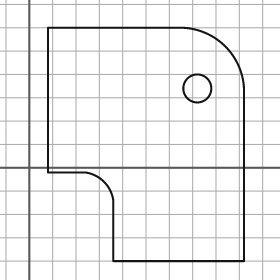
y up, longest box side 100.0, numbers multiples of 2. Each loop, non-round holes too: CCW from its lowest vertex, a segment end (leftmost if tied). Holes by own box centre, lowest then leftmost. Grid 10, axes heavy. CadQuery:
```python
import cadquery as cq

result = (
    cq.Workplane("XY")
    .moveTo(36.0, -40.0)
    .lineTo(92.0, -40.0)
    .lineTo(92.0, 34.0)
    .threePointArc((84.0, 52.0), (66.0, 60.0))
    .lineTo(8.0, 60.0)
    .lineTo(8.0, -2.0)
    .lineTo(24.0, -2.0)
    .threePointArc((32.0, -6.0), (36.0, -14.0))
    .close()
    .moveTo(72.0, 34.0)
    .circle(6.0)
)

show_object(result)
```